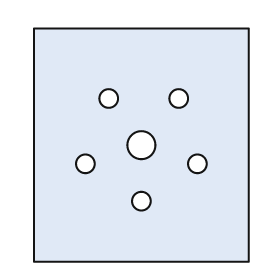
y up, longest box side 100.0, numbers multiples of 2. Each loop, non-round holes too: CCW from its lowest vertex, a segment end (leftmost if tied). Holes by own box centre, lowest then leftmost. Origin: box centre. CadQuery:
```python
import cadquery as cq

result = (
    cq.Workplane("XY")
    .moveTo(-46.0, -50.0)
    .lineTo(46.0, -50.0)
    .lineTo(46.0, 50.0)
    .lineTo(-46.0, 50.0)
    .close()
    .moveTo(0.0, -24.0)
    .circle(4.0)
    .moveTo(-24.0, -8.0)
    .circle(4.0)
    .moveTo(24.0, -8.0)
    .circle(4.0)
    .moveTo(0.0, 0.0)
    .circle(6.0)
    .moveTo(-14.0, 20.0)
    .circle(4.0)
    .moveTo(16.0, 20.0)
    .circle(4.0)
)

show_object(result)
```